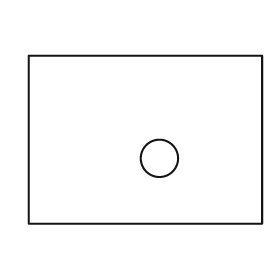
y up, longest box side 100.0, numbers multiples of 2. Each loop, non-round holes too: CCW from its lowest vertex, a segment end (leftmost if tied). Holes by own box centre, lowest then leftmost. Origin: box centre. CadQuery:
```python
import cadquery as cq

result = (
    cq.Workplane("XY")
    .moveTo(-50.0, -36.0)
    .lineTo(50.0, -36.0)
    .lineTo(50.0, 36.0)
    .lineTo(-50.0, 36.0)
    .close()
    .moveTo(6.0, -8.0)
    .circle(8.0)
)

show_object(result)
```